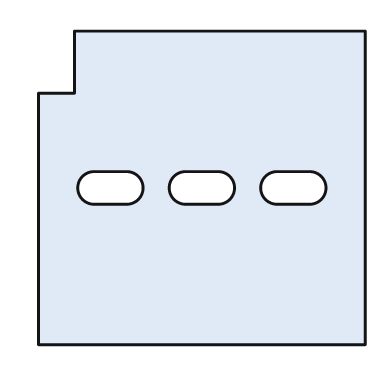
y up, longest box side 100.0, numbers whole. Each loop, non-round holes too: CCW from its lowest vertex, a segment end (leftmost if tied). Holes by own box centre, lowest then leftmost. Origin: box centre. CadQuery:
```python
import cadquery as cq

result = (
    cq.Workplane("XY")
    .moveTo(-50.0, -48.0)
    .lineTo(50.0, -48.0)
    .lineTo(50.0, 48.0)
    .lineTo(-39.0, 48.0)
    .lineTo(-39.0, 29.0)
    .lineTo(-50.0, 29.0)
    .close()
    .moveTo(-33.0, -5.0)
    .lineTo(-23.0, -5.0)
    .threePointArc((-18.0, 0.0), (-23.0, 5.0))
    .lineTo(-33.0, 5.0)
    .threePointArc((-38.0, 0.0), (-33.0, -5.0))
    .close()
    .moveTo(-5.0, -5.0)
    .lineTo(5.0, -5.0)
    .threePointArc((10.0, 0.0), (5.0, 5.0))
    .lineTo(-5.0, 5.0)
    .threePointArc((-10.0, 0.0), (-5.0, -5.0))
    .close()
    .moveTo(23.0, -5.0)
    .lineTo(33.0, -5.0)
    .threePointArc((38.0, 0.0), (33.0, 5.0))
    .lineTo(23.0, 5.0)
    .threePointArc((18.0, 0.0), (23.0, -5.0))
    .close()
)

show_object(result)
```